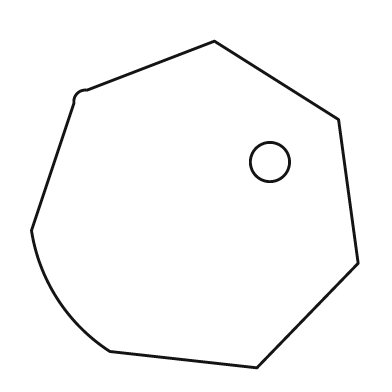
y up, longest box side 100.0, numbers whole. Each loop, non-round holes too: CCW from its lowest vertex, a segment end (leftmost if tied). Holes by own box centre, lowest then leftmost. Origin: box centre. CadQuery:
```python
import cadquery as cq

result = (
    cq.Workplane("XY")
    .moveTo(19.0, -50.0)
    .lineTo(50.0, -18.0)
    .lineTo(44.0, 26.0)
    .lineTo(6.0, 50.0)
    .lineTo(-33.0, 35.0)
    .threePointArc((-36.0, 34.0), (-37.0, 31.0))
    .lineTo(-50.0, -8.0)
    .threePointArc((-42.0, -29.0), (-26.0, -45.0))
    .close()
    .moveTo(23.0, 13.0)
    .circle(6.0)
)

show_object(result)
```